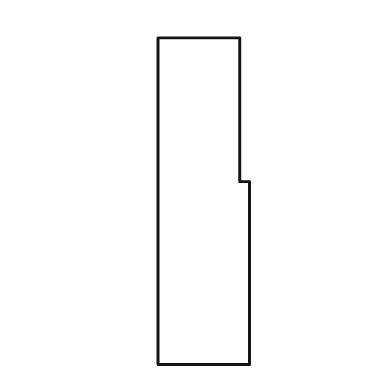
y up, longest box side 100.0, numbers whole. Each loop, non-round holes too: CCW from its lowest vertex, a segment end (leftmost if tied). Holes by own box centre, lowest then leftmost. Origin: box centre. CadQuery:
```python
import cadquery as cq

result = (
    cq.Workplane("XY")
    .moveTo(-14.0, -50.0)
    .lineTo(14.0, -50.0)
    .lineTo(14.0, 6.0)
    .lineTo(11.0, 6.0)
    .lineTo(11.0, 50.0)
    .lineTo(-14.0, 50.0)
    .close()
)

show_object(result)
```